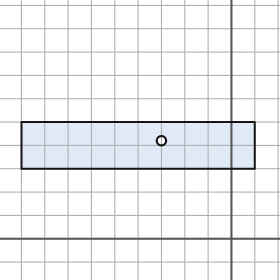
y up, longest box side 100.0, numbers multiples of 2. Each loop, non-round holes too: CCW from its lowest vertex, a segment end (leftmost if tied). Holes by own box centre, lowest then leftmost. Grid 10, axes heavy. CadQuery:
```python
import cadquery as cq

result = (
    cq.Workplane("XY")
    .moveTo(-90.0, 30.0)
    .lineTo(10.0, 30.0)
    .lineTo(10.0, 50.0)
    .lineTo(-90.0, 50.0)
    .close()
    .moveTo(-30.0, 42.0)
    .circle(2.0)
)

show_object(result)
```